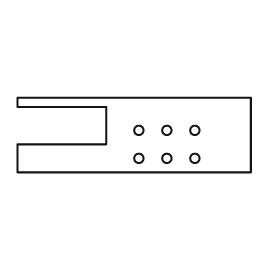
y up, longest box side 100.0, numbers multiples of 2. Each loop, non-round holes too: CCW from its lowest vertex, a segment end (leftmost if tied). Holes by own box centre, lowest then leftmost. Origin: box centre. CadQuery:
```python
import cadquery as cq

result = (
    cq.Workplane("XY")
    .moveTo(-50.0, -16.0)
    .lineTo(50.0, -16.0)
    .lineTo(50.0, 16.0)
    .lineTo(-50.0, 16.0)
    .lineTo(-50.0, 12.0)
    .lineTo(-12.0, 12.0)
    .lineTo(-12.0, -4.0)
    .lineTo(-50.0, -4.0)
    .close()
    .moveTo(2.0, -10.0)
    .circle(2.0)
    .moveTo(14.0, -10.0)
    .circle(2.0)
    .moveTo(26.0, -10.0)
    .circle(2.0)
    .moveTo(2.0, 2.0)
    .circle(2.0)
    .moveTo(14.0, 2.0)
    .circle(2.0)
    .moveTo(26.0, 2.0)
    .circle(2.0)
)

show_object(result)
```